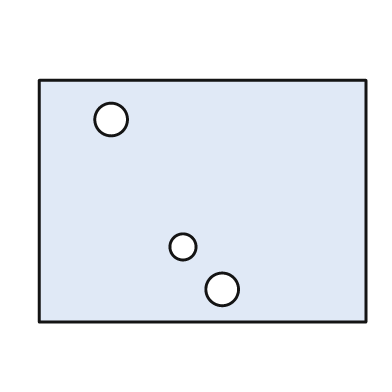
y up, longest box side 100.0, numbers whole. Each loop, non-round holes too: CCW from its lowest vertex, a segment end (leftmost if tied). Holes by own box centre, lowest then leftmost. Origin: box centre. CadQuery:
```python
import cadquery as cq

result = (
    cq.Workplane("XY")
    .moveTo(-50.0, -37.0)
    .lineTo(50.0, -37.0)
    .lineTo(50.0, 37.0)
    .lineTo(-50.0, 37.0)
    .close()
    .moveTo(6.0, -27.0)
    .circle(5.0)
    .moveTo(-6.0, -14.0)
    .circle(4.0)
    .moveTo(-28.0, 25.0)
    .circle(5.0)
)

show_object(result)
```